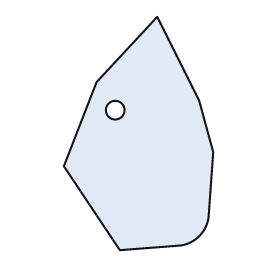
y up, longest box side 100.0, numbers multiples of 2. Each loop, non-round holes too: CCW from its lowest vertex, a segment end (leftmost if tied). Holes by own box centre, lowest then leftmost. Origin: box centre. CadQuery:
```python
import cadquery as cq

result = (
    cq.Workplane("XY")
    .moveTo(-8.0, -50.0)
    .lineTo(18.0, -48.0)
    .threePointArc((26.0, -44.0), (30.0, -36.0))
    .lineTo(32.0, -8.0)
    .lineTo(26.0, 14.0)
    .lineTo(8.0, 50.0)
    .lineTo(-18.0, 22.0)
    .lineTo(-32.0, -14.0)
    .close()
    .moveTo(-10.0, 10.0)
    .circle(4.0)
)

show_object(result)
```